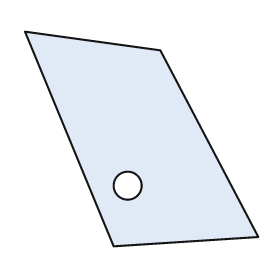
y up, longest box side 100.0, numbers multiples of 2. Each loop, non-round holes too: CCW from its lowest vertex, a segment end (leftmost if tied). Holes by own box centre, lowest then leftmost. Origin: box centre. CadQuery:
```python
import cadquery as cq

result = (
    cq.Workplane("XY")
    .moveTo(-12.0, -46.0)
    .lineTo(50.0, -42.0)
    .lineTo(8.0, 38.0)
    .lineTo(-50.0, 46.0)
    .close()
    .moveTo(-6.0, -20.0)
    .circle(6.0)
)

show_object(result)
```